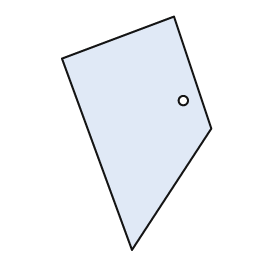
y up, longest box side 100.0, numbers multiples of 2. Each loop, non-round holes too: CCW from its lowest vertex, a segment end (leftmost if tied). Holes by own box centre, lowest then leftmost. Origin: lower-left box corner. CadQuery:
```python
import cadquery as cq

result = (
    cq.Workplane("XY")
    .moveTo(30.0, 0.0)
    .lineTo(64.0, 52.0)
    .lineTo(48.0, 100.0)
    .lineTo(0.0, 82.0)
    .close()
    .moveTo(52.0, 64.0)
    .circle(2.0)
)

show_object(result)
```